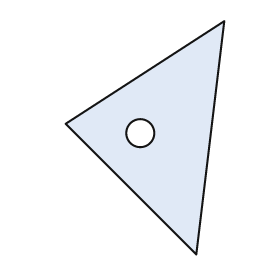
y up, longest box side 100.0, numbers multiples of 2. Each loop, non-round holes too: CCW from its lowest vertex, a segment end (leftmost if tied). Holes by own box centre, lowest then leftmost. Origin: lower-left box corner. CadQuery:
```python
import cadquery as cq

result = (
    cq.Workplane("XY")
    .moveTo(56.0, 0.0)
    .lineTo(68.0, 100.0)
    .lineTo(0.0, 56.0)
    .close()
    .moveTo(32.0, 52.0)
    .circle(6.0)
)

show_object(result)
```